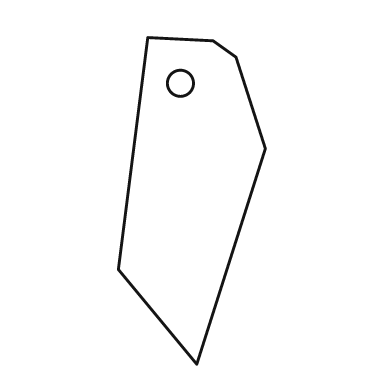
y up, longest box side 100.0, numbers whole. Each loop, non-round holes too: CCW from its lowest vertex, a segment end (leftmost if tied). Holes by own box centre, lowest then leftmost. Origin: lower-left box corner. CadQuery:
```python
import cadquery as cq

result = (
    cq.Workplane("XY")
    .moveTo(24.0, 0.0)
    .lineTo(45.0, 66.0)
    .lineTo(36.0, 94.0)
    .lineTo(29.0, 99.0)
    .lineTo(9.0, 100.0)
    .lineTo(0.0, 29.0)
    .close()
    .moveTo(19.0, 86.0)
    .circle(4.0)
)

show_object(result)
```